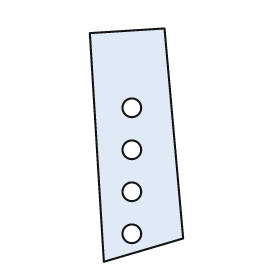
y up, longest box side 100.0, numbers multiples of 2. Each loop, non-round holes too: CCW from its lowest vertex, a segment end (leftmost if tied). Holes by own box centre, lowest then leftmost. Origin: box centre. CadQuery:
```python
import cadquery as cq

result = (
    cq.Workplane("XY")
    .moveTo(-14.0, -50.0)
    .lineTo(20.0, -40.0)
    .lineTo(12.0, 50.0)
    .lineTo(-20.0, 48.0)
    .close()
    .moveTo(-2.0, -38.0)
    .circle(4.0)
    .moveTo(-2.0, -20.0)
    .circle(4.0)
    .moveTo(-2.0, -2.0)
    .circle(4.0)
    .moveTo(-2.0, 16.0)
    .circle(4.0)
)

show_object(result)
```